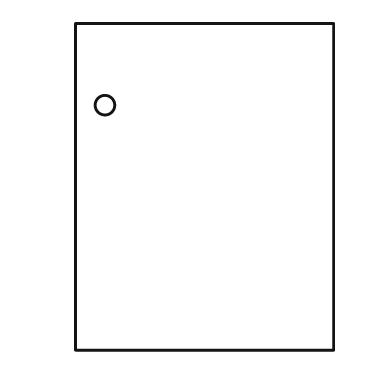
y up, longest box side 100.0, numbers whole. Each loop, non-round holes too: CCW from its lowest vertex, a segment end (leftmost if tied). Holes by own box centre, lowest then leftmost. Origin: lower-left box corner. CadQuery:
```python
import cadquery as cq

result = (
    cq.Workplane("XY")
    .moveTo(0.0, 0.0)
    .lineTo(79.0, 0.0)
    .lineTo(79.0, 100.0)
    .lineTo(0.0, 100.0)
    .close()
    .moveTo(9.0, 75.0)
    .circle(3.0)
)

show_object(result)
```